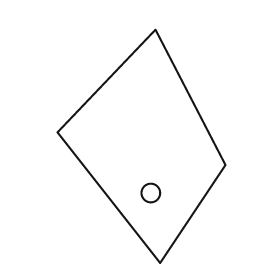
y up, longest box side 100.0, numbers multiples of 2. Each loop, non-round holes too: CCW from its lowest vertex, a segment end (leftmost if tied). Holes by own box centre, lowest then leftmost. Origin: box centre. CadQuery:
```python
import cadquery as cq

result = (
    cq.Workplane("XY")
    .moveTo(8.0, -50.0)
    .lineTo(36.0, -8.0)
    .lineTo(6.0, 50.0)
    .lineTo(-36.0, 6.0)
    .close()
    .moveTo(4.0, -20.0)
    .circle(4.0)
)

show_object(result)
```